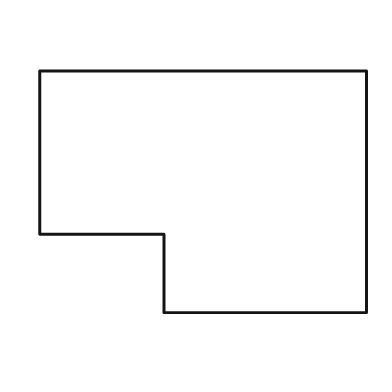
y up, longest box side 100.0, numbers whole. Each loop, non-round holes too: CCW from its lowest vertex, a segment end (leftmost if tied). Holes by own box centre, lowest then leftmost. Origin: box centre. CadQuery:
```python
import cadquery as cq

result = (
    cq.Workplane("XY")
    .moveTo(-12.0, -37.0)
    .lineTo(50.0, -37.0)
    .lineTo(50.0, 37.0)
    .lineTo(-50.0, 37.0)
    .lineTo(-50.0, -13.0)
    .lineTo(-12.0, -13.0)
    .close()
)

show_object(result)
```